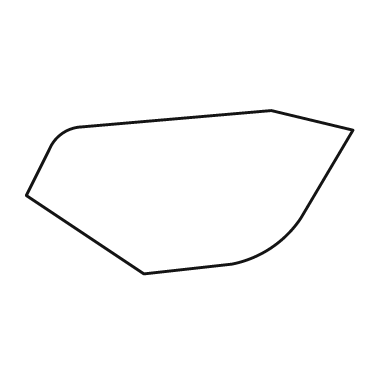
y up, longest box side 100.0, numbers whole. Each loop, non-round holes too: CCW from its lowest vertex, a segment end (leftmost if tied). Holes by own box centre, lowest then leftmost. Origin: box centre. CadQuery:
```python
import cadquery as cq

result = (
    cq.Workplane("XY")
    .moveTo(-14.0, -25.0)
    .lineTo(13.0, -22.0)
    .threePointArc((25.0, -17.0), (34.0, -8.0))
    .lineTo(50.0, 19.0)
    .lineTo(25.0, 25.0)
    .lineTo(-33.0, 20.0)
    .threePointArc((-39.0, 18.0), (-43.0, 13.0))
    .lineTo(-50.0, -1.0)
    .close()
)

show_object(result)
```